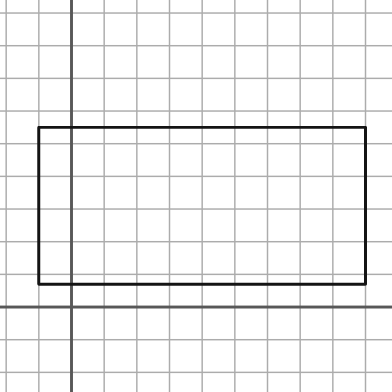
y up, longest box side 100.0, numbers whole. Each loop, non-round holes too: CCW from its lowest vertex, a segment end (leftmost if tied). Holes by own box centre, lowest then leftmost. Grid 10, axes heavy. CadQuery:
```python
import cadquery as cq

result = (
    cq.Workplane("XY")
    .moveTo(-10.0, 7.0)
    .lineTo(90.0, 7.0)
    .lineTo(90.0, 55.0)
    .lineTo(-10.0, 55.0)
    .close()
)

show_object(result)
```